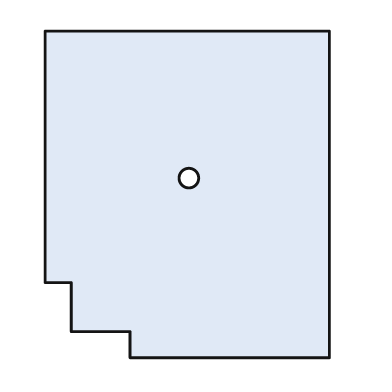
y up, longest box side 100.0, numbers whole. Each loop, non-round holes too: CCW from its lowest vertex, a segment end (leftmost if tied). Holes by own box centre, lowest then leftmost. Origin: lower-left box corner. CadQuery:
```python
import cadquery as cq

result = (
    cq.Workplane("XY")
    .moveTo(26.0, 0.0)
    .lineTo(87.0, 0.0)
    .lineTo(87.0, 100.0)
    .lineTo(0.0, 100.0)
    .lineTo(0.0, 23.0)
    .lineTo(8.0, 23.0)
    .lineTo(8.0, 8.0)
    .lineTo(26.0, 8.0)
    .close()
    .moveTo(44.0, 55.0)
    .circle(3.0)
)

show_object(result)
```